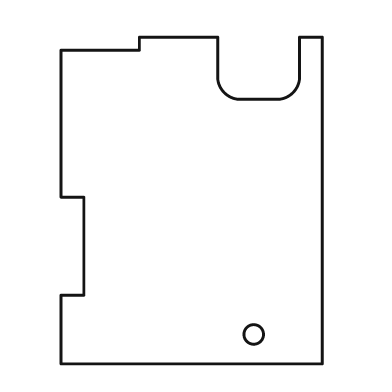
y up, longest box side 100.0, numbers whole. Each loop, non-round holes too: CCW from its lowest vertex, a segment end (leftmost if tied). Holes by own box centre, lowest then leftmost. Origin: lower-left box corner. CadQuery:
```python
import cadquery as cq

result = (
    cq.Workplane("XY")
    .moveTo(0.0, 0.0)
    .lineTo(80.0, 0.0)
    .lineTo(80.0, 100.0)
    .lineTo(73.0, 100.0)
    .lineTo(73.0, 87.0)
    .threePointArc((71.0, 83.0), (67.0, 81.0))
    .lineTo(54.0, 81.0)
    .threePointArc((50.0, 83.0), (48.0, 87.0))
    .lineTo(48.0, 100.0)
    .lineTo(24.0, 100.0)
    .lineTo(24.0, 96.0)
    .lineTo(0.0, 96.0)
    .lineTo(0.0, 51.0)
    .lineTo(7.0, 51.0)
    .lineTo(7.0, 21.0)
    .lineTo(0.0, 21.0)
    .close()
    .moveTo(59.0, 9.0)
    .circle(3.0)
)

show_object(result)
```